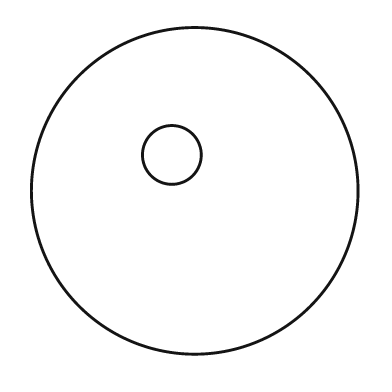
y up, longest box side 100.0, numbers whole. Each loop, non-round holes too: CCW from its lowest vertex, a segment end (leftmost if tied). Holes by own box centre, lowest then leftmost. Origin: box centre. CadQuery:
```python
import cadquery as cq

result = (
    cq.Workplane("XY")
    .moveTo(0.0, 0.0)
    .circle(50.0)
    .moveTo(-7.0, 11.0)
    .circle(9.0)
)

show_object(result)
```